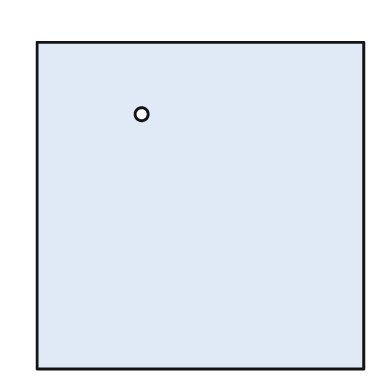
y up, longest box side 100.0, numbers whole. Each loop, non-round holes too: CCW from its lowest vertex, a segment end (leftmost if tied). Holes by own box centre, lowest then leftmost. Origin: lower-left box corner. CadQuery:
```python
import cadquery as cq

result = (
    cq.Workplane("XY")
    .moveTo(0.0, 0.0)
    .lineTo(100.0, 0.0)
    .lineTo(100.0, 100.0)
    .lineTo(0.0, 100.0)
    .close()
    .moveTo(32.0, 78.0)
    .circle(2.0)
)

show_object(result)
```